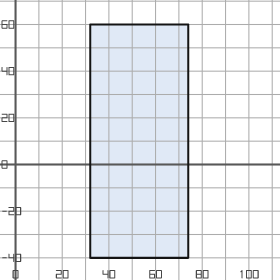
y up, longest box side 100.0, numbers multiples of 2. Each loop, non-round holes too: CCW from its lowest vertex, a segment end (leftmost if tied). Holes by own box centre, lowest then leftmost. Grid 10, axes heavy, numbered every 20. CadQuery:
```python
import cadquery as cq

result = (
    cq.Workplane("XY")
    .moveTo(32.0, -40.0)
    .lineTo(74.0, -40.0)
    .lineTo(74.0, 60.0)
    .lineTo(32.0, 60.0)
    .close()
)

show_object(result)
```